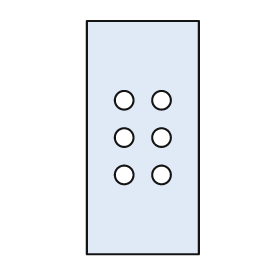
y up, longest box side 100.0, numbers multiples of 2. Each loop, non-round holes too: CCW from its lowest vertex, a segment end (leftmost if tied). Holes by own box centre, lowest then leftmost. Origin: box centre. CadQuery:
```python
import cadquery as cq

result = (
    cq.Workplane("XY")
    .moveTo(-24.0, -50.0)
    .lineTo(24.0, -50.0)
    .lineTo(24.0, 50.0)
    .lineTo(-24.0, 50.0)
    .close()
    .moveTo(-8.0, -16.0)
    .circle(4.0)
    .moveTo(8.0, -16.0)
    .circle(4.0)
    .moveTo(-8.0, 0.0)
    .circle(4.0)
    .moveTo(8.0, 0.0)
    .circle(4.0)
    .moveTo(-8.0, 16.0)
    .circle(4.0)
    .moveTo(8.0, 16.0)
    .circle(4.0)
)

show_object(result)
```